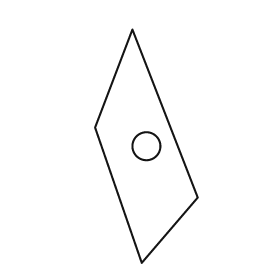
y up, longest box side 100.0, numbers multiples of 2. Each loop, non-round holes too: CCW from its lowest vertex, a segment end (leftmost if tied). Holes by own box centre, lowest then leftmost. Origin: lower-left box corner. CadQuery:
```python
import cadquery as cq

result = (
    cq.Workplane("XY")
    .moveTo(20.0, 0.0)
    .lineTo(44.0, 28.0)
    .lineTo(16.0, 100.0)
    .lineTo(0.0, 58.0)
    .close()
    .moveTo(22.0, 50.0)
    .circle(6.0)
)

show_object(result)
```